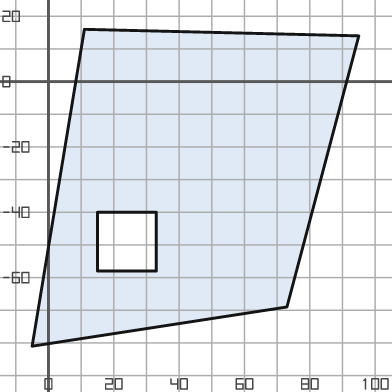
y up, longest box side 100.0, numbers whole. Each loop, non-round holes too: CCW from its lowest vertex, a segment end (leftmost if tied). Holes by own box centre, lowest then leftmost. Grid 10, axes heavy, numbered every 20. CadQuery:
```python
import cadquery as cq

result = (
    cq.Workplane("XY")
    .moveTo(-5.0, -81.0)
    .lineTo(73.0, -69.0)
    .lineTo(95.0, 14.0)
    .lineTo(11.0, 16.0)
    .close()
    .moveTo(15.0, -58.0)
    .lineTo(33.0, -58.0)
    .lineTo(33.0, -40.0)
    .lineTo(15.0, -40.0)
    .close()
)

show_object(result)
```